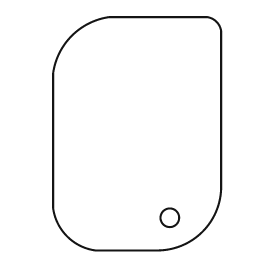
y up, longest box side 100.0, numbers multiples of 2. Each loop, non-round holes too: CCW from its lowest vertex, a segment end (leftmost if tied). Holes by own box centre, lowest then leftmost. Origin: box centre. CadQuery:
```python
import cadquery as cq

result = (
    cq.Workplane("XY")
    .moveTo(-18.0, -50.0)
    .lineTo(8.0, -50.0)
    .threePointArc((28.0, -42.0), (36.0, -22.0))
    .lineTo(36.0, 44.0)
    .threePointArc((34.0, 48.0), (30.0, 50.0))
    .lineTo(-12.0, 50.0)
    .threePointArc((-28.0, 42.0), (-36.0, 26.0))
    .lineTo(-36.0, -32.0)
    .threePointArc((-30.0, -44.0), (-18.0, -50.0))
    .close()
    .moveTo(14.0, -36.0)
    .circle(4.0)
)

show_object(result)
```